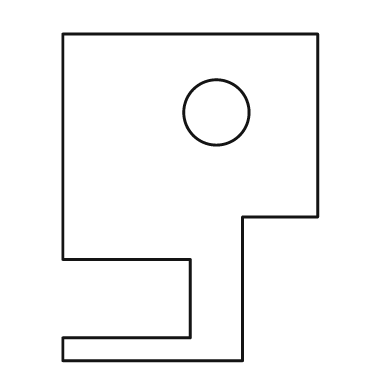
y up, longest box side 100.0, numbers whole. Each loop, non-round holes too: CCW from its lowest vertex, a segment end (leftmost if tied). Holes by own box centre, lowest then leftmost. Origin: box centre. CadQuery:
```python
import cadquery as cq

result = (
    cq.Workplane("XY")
    .moveTo(-39.0, -50.0)
    .lineTo(16.0, -50.0)
    .lineTo(16.0, -6.0)
    .lineTo(39.0, -6.0)
    .lineTo(39.0, 50.0)
    .lineTo(-39.0, 50.0)
    .lineTo(-39.0, -19.0)
    .lineTo(0.0, -19.0)
    .lineTo(0.0, -43.0)
    .lineTo(-39.0, -43.0)
    .close()
    .moveTo(8.0, 26.0)
    .circle(10.0)
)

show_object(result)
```